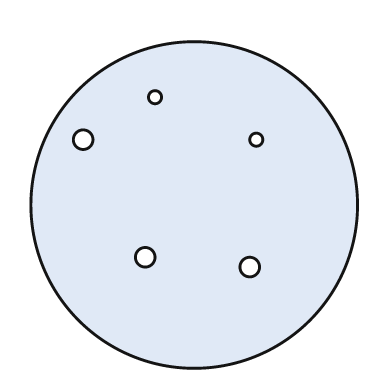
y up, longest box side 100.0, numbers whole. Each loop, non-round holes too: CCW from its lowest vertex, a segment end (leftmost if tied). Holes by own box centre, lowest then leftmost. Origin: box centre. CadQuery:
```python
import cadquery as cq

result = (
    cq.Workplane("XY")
    .moveTo(0.0, 0.0)
    .circle(50.0)
    .moveTo(17.0, -19.0)
    .circle(3.0)
    .moveTo(-15.0, -16.0)
    .circle(3.0)
    .moveTo(-34.0, 20.0)
    .circle(3.0)
    .moveTo(19.0, 20.0)
    .circle(2.0)
    .moveTo(-12.0, 33.0)
    .circle(2.0)
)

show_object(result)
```